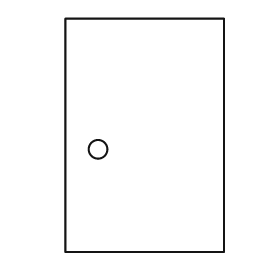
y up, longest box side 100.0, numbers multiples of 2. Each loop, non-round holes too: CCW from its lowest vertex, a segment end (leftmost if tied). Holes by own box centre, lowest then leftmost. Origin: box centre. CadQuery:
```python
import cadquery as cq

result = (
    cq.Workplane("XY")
    .moveTo(-34.0, -50.0)
    .lineTo(34.0, -50.0)
    .lineTo(34.0, 50.0)
    .lineTo(-34.0, 50.0)
    .close()
    .moveTo(-20.0, -6.0)
    .circle(4.0)
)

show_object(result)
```